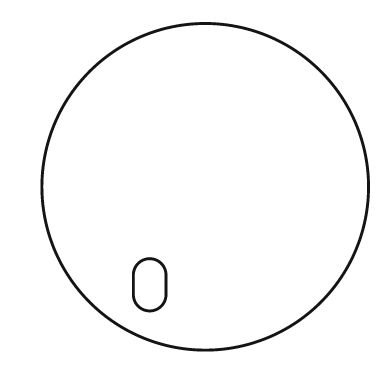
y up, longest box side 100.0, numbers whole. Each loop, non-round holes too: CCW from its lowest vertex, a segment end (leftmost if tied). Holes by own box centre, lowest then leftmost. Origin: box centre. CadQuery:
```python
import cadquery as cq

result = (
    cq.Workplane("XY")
    .moveTo(0.0, 0.0)
    .circle(50.0)
    .moveTo(-22.0, -33.0)
    .threePointArc((-17.0, -38.0), (-12.0, -33.0))
    .lineTo(-12.0, -27.0)
    .threePointArc((-17.0, -22.0), (-22.0, -27.0))
    .close()
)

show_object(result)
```